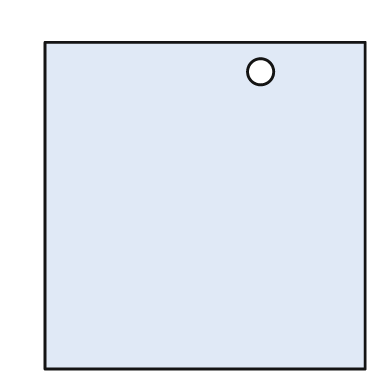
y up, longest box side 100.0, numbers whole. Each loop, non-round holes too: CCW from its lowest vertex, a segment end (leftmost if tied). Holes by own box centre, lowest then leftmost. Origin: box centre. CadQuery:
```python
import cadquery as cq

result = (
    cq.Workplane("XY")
    .moveTo(-49.0, -50.0)
    .lineTo(49.0, -50.0)
    .lineTo(49.0, 50.0)
    .lineTo(-49.0, 50.0)
    .close()
    .moveTo(17.0, 41.0)
    .circle(4.0)
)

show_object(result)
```